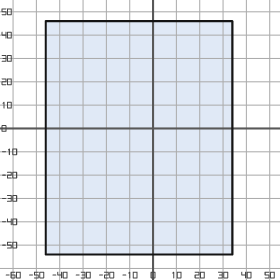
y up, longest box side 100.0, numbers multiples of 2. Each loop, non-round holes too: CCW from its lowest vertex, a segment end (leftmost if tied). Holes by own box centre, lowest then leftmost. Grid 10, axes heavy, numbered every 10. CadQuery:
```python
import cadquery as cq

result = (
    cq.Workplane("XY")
    .moveTo(-46.0, -54.0)
    .lineTo(34.0, -54.0)
    .lineTo(34.0, 46.0)
    .lineTo(-46.0, 46.0)
    .close()
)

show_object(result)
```